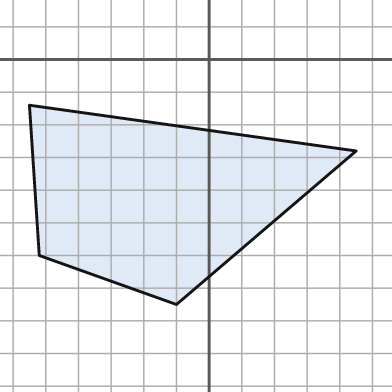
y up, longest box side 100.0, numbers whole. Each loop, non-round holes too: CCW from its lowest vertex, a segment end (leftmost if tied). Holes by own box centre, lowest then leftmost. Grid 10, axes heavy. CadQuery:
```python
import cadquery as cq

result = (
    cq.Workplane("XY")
    .moveTo(-10.0, -75.0)
    .lineTo(45.0, -28.0)
    .lineTo(-55.0, -14.0)
    .lineTo(-52.0, -60.0)
    .close()
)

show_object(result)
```